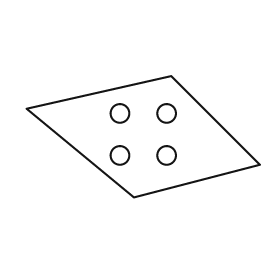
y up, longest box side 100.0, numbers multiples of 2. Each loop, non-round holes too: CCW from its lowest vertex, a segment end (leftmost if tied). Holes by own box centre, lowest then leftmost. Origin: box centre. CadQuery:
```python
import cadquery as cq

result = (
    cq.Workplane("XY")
    .moveTo(-4.0, -26.0)
    .lineTo(50.0, -12.0)
    .lineTo(12.0, 26.0)
    .lineTo(-50.0, 12.0)
    .close()
    .moveTo(-10.0, -8.0)
    .circle(4.0)
    .moveTo(10.0, -8.0)
    .circle(4.0)
    .moveTo(-10.0, 10.0)
    .circle(4.0)
    .moveTo(10.0, 10.0)
    .circle(4.0)
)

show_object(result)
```